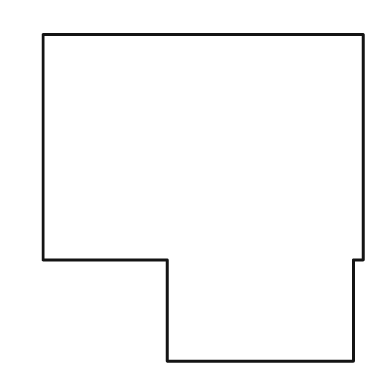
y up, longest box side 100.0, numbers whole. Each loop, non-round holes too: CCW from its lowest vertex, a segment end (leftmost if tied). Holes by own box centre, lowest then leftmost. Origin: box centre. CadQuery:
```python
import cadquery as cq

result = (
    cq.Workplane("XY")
    .moveTo(-11.0, -50.0)
    .lineTo(46.0, -50.0)
    .lineTo(46.0, -19.0)
    .lineTo(49.0, -19.0)
    .lineTo(49.0, 50.0)
    .lineTo(-49.0, 50.0)
    .lineTo(-49.0, -19.0)
    .lineTo(-11.0, -19.0)
    .close()
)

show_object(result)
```